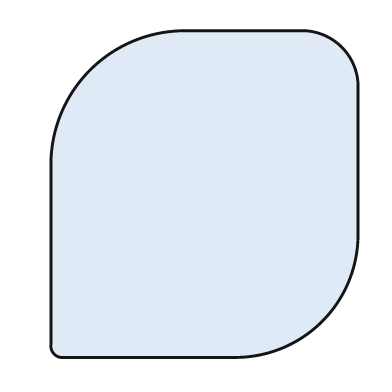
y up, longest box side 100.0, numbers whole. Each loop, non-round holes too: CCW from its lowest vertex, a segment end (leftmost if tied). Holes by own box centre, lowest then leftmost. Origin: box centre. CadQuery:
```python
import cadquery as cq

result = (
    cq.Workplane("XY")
    .moveTo(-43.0, -50.0)
    .lineTo(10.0, -50.0)
    .threePointArc((36.0, -39.0), (47.0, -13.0))
    .lineTo(47.0, 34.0)
    .threePointArc((42.0, 45.0), (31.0, 50.0))
    .lineTo(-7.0, 50.0)
    .threePointArc((-35.0, 38.0), (-47.0, 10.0))
    .lineTo(-47.0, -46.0)
    .threePointArc((-46.0, -49.0), (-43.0, -50.0))
    .close()
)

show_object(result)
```